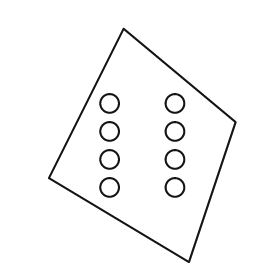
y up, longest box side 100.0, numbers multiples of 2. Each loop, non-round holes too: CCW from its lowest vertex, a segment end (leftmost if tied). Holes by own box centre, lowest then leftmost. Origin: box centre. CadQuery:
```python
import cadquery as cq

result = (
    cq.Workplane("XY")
    .moveTo(20.0, -50.0)
    .lineTo(40.0, 10.0)
    .lineTo(-8.0, 50.0)
    .lineTo(-40.0, -14.0)
    .close()
    .moveTo(-14.0, -18.0)
    .circle(4.0)
    .moveTo(14.0, -18.0)
    .circle(4.0)
    .moveTo(-14.0, -6.0)
    .circle(4.0)
    .moveTo(14.0, -6.0)
    .circle(4.0)
    .moveTo(-14.0, 6.0)
    .circle(4.0)
    .moveTo(14.0, 6.0)
    .circle(4.0)
    .moveTo(-14.0, 18.0)
    .circle(4.0)
    .moveTo(14.0, 18.0)
    .circle(4.0)
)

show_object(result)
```